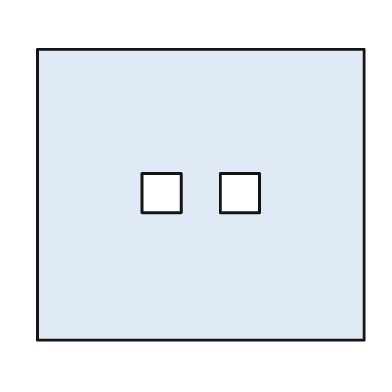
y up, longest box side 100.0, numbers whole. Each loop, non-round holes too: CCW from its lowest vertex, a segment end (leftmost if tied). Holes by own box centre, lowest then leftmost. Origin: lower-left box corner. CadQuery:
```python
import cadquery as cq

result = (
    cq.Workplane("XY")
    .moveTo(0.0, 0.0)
    .lineTo(100.0, 0.0)
    .lineTo(100.0, 89.0)
    .lineTo(0.0, 89.0)
    .close()
    .moveTo(32.0, 39.0)
    .lineTo(44.0, 39.0)
    .lineTo(44.0, 51.0)
    .lineTo(32.0, 51.0)
    .close()
    .moveTo(56.0, 39.0)
    .lineTo(68.0, 39.0)
    .lineTo(68.0, 51.0)
    .lineTo(56.0, 51.0)
    .close()
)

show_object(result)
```